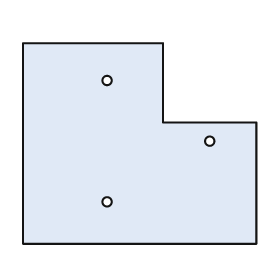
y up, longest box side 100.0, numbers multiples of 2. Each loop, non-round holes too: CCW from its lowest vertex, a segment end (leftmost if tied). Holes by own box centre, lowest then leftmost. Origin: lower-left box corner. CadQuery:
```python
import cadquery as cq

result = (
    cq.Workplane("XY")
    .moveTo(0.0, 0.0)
    .lineTo(100.0, 0.0)
    .lineTo(100.0, 52.0)
    .lineTo(60.0, 52.0)
    .lineTo(60.0, 86.0)
    .lineTo(0.0, 86.0)
    .close()
    .moveTo(36.0, 18.0)
    .circle(2.0)
    .moveTo(80.0, 44.0)
    .circle(2.0)
    .moveTo(36.0, 70.0)
    .circle(2.0)
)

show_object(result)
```